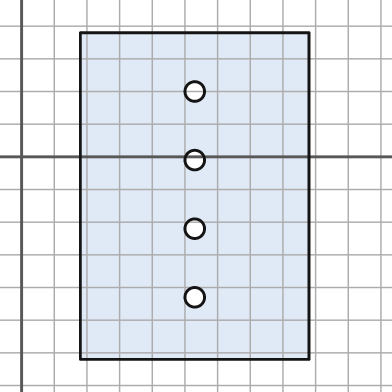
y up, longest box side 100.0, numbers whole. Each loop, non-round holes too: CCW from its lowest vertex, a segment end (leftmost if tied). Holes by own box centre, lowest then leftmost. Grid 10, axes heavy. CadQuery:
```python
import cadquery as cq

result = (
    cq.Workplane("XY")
    .moveTo(18.0, -62.0)
    .lineTo(88.0, -62.0)
    .lineTo(88.0, 38.0)
    .lineTo(18.0, 38.0)
    .close()
    .moveTo(53.0, -43.0)
    .circle(3.0)
    .moveTo(53.0, -22.0)
    .circle(3.0)
    .moveTo(53.0, -1.0)
    .circle(3.0)
    .moveTo(53.0, 20.0)
    .circle(3.0)
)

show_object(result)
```